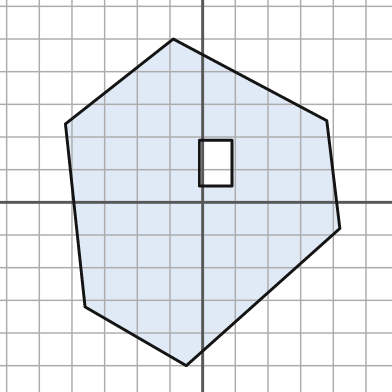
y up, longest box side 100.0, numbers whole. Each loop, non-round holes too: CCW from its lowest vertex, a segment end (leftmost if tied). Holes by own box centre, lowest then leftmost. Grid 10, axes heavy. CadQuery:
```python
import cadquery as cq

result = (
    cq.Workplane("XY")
    .moveTo(-5.0, -50.0)
    .lineTo(42.0, -8.0)
    .lineTo(38.0, 25.0)
    .lineTo(-9.0, 50.0)
    .lineTo(-42.0, 24.0)
    .lineTo(-36.0, -32.0)
    .close()
    .moveTo(-1.0, 5.0)
    .lineTo(9.0, 5.0)
    .lineTo(9.0, 19.0)
    .lineTo(-1.0, 19.0)
    .close()
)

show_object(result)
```